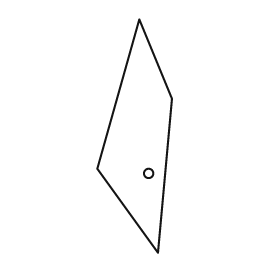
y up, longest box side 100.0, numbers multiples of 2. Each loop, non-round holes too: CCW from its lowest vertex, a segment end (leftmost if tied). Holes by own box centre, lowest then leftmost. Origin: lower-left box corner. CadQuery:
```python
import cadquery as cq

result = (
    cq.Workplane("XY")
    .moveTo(26.0, 0.0)
    .lineTo(32.0, 66.0)
    .lineTo(18.0, 100.0)
    .lineTo(0.0, 36.0)
    .close()
    .moveTo(22.0, 34.0)
    .circle(2.0)
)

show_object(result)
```